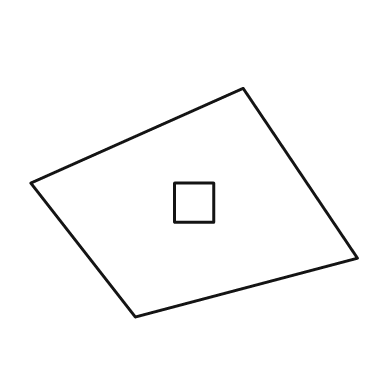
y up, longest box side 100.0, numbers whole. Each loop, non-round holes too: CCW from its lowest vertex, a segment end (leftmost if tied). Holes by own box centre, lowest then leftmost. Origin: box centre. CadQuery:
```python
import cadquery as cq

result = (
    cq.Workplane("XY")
    .moveTo(-18.0, -35.0)
    .lineTo(50.0, -17.0)
    .lineTo(15.0, 35.0)
    .lineTo(-50.0, 6.0)
    .close()
    .moveTo(-6.0, -6.0)
    .lineTo(6.0, -6.0)
    .lineTo(6.0, 6.0)
    .lineTo(-6.0, 6.0)
    .close()
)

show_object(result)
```